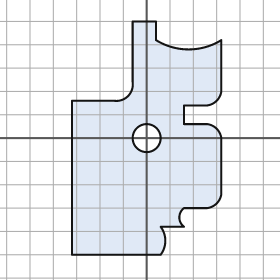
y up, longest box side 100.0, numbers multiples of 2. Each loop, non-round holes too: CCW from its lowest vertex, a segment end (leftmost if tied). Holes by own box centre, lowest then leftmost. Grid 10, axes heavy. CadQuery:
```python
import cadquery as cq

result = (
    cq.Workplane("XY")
    .moveTo(-32.0, -50.0)
    .lineTo(6.0, -50.0)
    .threePointArc((8.0, -44.0), (6.0, -38.0))
    .lineTo(16.0, -38.0)
    .threePointArc((14.0, -34.0), (16.0, -30.0))
    .lineTo(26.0, -30.0)
    .threePointArc((30.0, -28.0), (32.0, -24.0))
    .lineTo(32.0, 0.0)
    .threePointArc((30.0, 4.0), (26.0, 6.0))
    .lineTo(16.0, 6.0)
    .lineTo(16.0, 14.0)
    .lineTo(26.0, 14.0)
    .threePointArc((30.0, 16.0), (32.0, 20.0))
    .lineTo(32.0, 42.0)
    .threePointArc((18.0, 38.0), (4.0, 42.0))
    .lineTo(4.0, 50.0)
    .lineTo(-6.0, 50.0)
    .lineTo(-6.0, 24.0)
    .threePointArc((-8.0, 18.0), (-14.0, 16.0))
    .lineTo(-32.0, 16.0)
    .close()
    .moveTo(0.0, 0.0)
    .circle(6.0)
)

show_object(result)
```